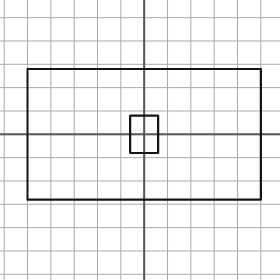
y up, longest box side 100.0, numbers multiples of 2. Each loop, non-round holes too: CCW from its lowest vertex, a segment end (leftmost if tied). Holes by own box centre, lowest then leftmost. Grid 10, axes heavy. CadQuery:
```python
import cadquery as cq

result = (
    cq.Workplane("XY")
    .moveTo(-50.0, -28.0)
    .lineTo(50.0, -28.0)
    .lineTo(50.0, 28.0)
    .lineTo(-50.0, 28.0)
    .close()
    .moveTo(-6.0, -8.0)
    .lineTo(6.0, -8.0)
    .lineTo(6.0, 8.0)
    .lineTo(-6.0, 8.0)
    .close()
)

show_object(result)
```